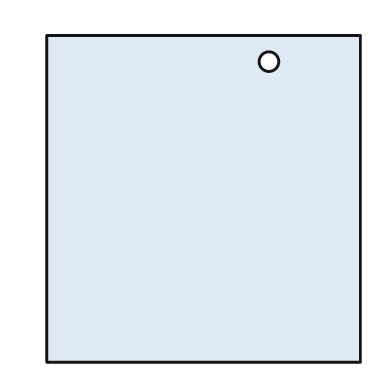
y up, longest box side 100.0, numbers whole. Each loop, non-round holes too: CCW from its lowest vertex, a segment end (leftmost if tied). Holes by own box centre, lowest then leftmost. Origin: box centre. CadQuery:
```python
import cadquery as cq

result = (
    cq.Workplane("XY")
    .moveTo(-48.0, -50.0)
    .lineTo(48.0, -50.0)
    .lineTo(48.0, 50.0)
    .lineTo(-48.0, 50.0)
    .close()
    .moveTo(20.0, 42.0)
    .circle(3.0)
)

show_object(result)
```